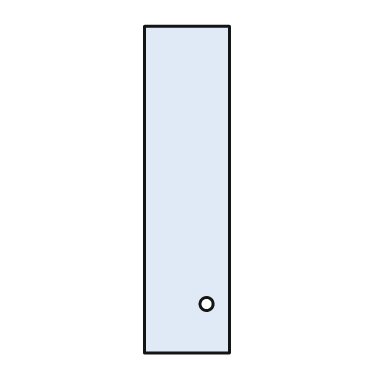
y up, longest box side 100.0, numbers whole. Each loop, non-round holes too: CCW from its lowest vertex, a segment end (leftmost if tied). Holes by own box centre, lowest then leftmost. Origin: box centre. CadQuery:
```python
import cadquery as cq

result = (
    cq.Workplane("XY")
    .moveTo(-13.0, -50.0)
    .lineTo(13.0, -50.0)
    .lineTo(13.0, 50.0)
    .lineTo(-13.0, 50.0)
    .close()
    .moveTo(6.0, -35.0)
    .circle(2.0)
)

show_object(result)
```